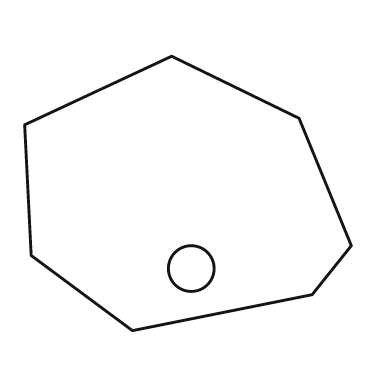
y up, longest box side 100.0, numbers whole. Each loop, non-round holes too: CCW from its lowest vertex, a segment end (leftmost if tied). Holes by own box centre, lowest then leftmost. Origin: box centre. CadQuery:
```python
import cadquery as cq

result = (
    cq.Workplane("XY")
    .moveTo(-17.0, -42.0)
    .lineTo(38.0, -31.0)
    .lineTo(50.0, -16.0)
    .lineTo(34.0, 23.0)
    .lineTo(-5.0, 42.0)
    .lineTo(-50.0, 21.0)
    .lineTo(-48.0, -19.0)
    .close()
    .moveTo(1.0, -23.0)
    .circle(7.0)
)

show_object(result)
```